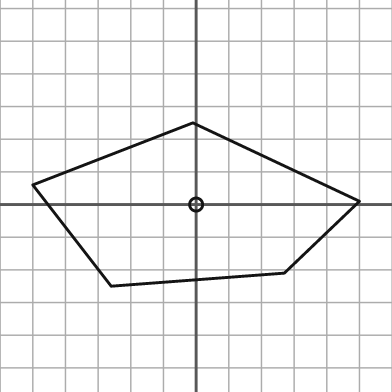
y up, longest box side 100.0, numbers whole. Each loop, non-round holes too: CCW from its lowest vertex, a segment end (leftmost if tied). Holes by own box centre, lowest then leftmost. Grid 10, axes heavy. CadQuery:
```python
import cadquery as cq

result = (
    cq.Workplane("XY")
    .moveTo(-26.0, -25.0)
    .lineTo(27.0, -21.0)
    .lineTo(50.0, 1.0)
    .lineTo(-1.0, 25.0)
    .lineTo(-50.0, 6.0)
    .close()
    .moveTo(0.0, 0.0)
    .circle(2.0)
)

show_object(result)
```